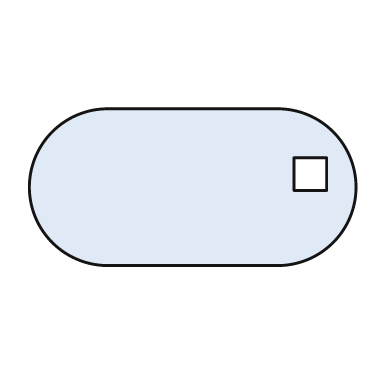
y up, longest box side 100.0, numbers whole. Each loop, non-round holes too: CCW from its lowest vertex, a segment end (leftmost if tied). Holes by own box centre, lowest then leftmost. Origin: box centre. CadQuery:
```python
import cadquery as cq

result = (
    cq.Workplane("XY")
    .moveTo(-26.0, -24.0)
    .lineTo(26.0, -24.0)
    .threePointArc((50.0, 0.0), (26.0, 24.0))
    .lineTo(-26.0, 24.0)
    .threePointArc((-50.0, 0.0), (-26.0, -24.0))
    .close()
    .moveTo(31.0, -1.0)
    .lineTo(41.0, -1.0)
    .lineTo(41.0, 9.0)
    .lineTo(31.0, 9.0)
    .close()
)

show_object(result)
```